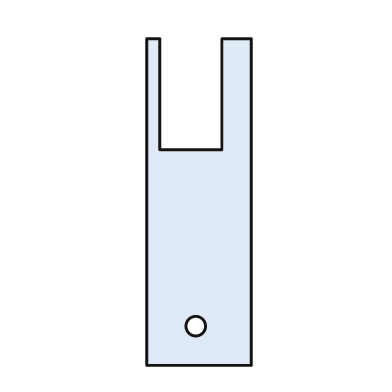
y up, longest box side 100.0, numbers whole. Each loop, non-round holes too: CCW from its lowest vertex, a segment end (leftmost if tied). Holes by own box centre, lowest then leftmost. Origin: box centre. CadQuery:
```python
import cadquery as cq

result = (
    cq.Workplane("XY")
    .moveTo(-16.0, -50.0)
    .lineTo(16.0, -50.0)
    .lineTo(16.0, 50.0)
    .lineTo(7.0, 50.0)
    .lineTo(7.0, 16.0)
    .lineTo(-12.0, 16.0)
    .lineTo(-12.0, 50.0)
    .lineTo(-16.0, 50.0)
    .close()
    .moveTo(-1.0, -38.0)
    .circle(3.0)
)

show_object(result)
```